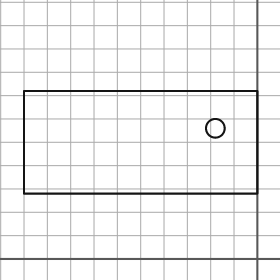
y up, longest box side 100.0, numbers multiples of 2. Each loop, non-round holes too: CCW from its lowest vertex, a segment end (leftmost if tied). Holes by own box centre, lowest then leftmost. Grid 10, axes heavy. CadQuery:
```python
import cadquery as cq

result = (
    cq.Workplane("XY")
    .moveTo(-100.0, 28.0)
    .lineTo(0.0, 28.0)
    .lineTo(0.0, 72.0)
    .lineTo(-100.0, 72.0)
    .close()
    .moveTo(-18.0, 56.0)
    .circle(4.0)
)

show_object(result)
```